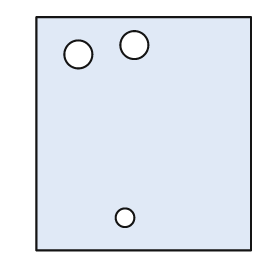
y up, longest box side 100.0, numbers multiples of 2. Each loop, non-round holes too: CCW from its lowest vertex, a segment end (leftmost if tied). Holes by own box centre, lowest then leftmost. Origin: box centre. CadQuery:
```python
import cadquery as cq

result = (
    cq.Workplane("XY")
    .moveTo(-46.0, -50.0)
    .lineTo(46.0, -50.0)
    .lineTo(46.0, 50.0)
    .lineTo(-46.0, 50.0)
    .close()
    .moveTo(-8.0, -36.0)
    .circle(4.0)
    .moveTo(-28.0, 34.0)
    .circle(6.0)
    .moveTo(-4.0, 38.0)
    .circle(6.0)
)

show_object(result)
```